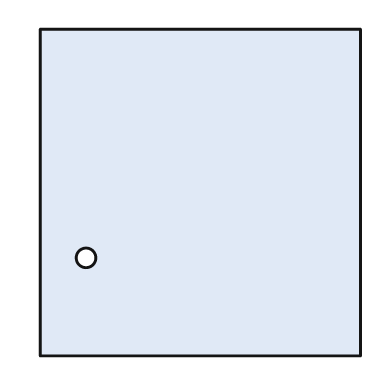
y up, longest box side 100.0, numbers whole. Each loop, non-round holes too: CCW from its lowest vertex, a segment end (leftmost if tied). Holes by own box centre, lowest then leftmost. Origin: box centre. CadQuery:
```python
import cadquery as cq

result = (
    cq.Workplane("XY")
    .moveTo(-49.0, -50.0)
    .lineTo(49.0, -50.0)
    .lineTo(49.0, 50.0)
    .lineTo(-49.0, 50.0)
    .close()
    .moveTo(-35.0, -20.0)
    .circle(3.0)
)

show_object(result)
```